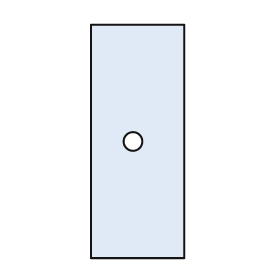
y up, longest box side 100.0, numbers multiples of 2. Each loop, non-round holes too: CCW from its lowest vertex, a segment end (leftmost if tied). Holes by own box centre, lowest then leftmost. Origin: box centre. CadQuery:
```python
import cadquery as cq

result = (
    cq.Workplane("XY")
    .moveTo(-20.0, -50.0)
    .lineTo(20.0, -50.0)
    .lineTo(20.0, 50.0)
    .lineTo(-20.0, 50.0)
    .close()
    .moveTo(-2.0, 0.0)
    .circle(4.0)
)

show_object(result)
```